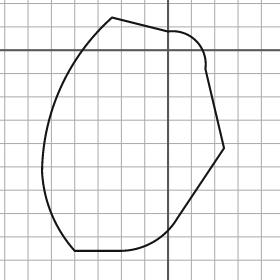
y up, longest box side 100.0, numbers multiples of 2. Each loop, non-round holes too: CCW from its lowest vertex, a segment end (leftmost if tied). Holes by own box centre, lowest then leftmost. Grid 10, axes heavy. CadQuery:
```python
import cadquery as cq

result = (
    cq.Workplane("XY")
    .moveTo(-40.0, -86.0)
    .lineTo(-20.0, -86.0)
    .threePointArc((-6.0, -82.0), (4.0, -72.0))
    .lineTo(24.0, -42.0)
    .lineTo(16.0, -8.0)
    .threePointArc((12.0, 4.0), (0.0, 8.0))
    .lineTo(-24.0, 14.0)
    .threePointArc((-46.0, -16.0), (-54.0, -52.0))
    .threePointArc((-50.0, -70.0), (-40.0, -86.0))
    .close()
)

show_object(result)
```